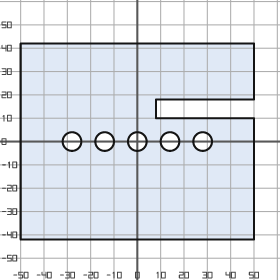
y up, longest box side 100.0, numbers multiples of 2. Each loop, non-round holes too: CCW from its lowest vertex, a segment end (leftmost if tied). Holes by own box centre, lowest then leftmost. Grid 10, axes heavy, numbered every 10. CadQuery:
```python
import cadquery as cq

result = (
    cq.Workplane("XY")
    .moveTo(-50.0, -42.0)
    .lineTo(50.0, -42.0)
    .lineTo(50.0, 10.0)
    .lineTo(8.0, 10.0)
    .lineTo(8.0, 18.0)
    .lineTo(50.0, 18.0)
    .lineTo(50.0, 42.0)
    .lineTo(-50.0, 42.0)
    .close()
    .moveTo(-28.0, 0.0)
    .circle(4.0)
    .moveTo(-14.0, 0.0)
    .circle(4.0)
    .moveTo(0.0, 0.0)
    .circle(4.0)
    .moveTo(14.0, 0.0)
    .circle(4.0)
    .moveTo(28.0, 0.0)
    .circle(4.0)
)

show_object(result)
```